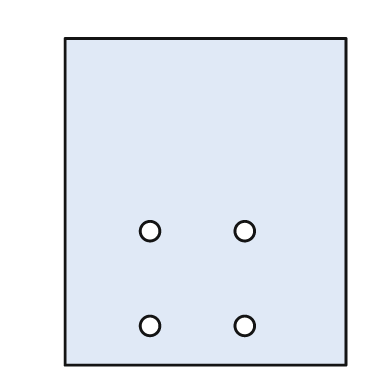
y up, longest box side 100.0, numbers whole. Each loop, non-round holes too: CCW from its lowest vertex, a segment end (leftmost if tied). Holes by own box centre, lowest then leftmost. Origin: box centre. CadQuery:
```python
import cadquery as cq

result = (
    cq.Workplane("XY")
    .moveTo(-43.0, -50.0)
    .lineTo(43.0, -50.0)
    .lineTo(43.0, 50.0)
    .lineTo(-43.0, 50.0)
    .close()
    .moveTo(-17.0, -38.0)
    .circle(3.0)
    .moveTo(12.0, -38.0)
    .circle(3.0)
    .moveTo(-17.0, -9.0)
    .circle(3.0)
    .moveTo(12.0, -9.0)
    .circle(3.0)
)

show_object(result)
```